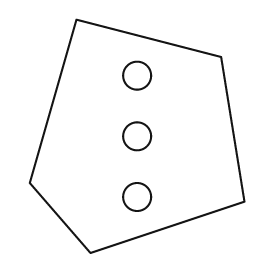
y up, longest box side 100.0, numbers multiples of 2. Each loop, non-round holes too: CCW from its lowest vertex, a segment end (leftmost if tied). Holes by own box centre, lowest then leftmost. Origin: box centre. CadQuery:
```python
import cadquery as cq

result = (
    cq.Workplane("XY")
    .moveTo(-20.0, -50.0)
    .lineTo(46.0, -28.0)
    .lineTo(36.0, 34.0)
    .lineTo(-26.0, 50.0)
    .lineTo(-46.0, -20.0)
    .close()
    .moveTo(0.0, -26.0)
    .circle(6.0)
    .moveTo(0.0, 0.0)
    .circle(6.0)
    .moveTo(0.0, 26.0)
    .circle(6.0)
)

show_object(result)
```